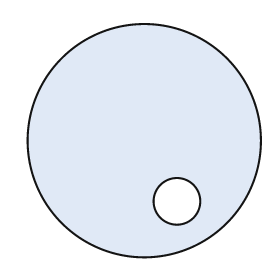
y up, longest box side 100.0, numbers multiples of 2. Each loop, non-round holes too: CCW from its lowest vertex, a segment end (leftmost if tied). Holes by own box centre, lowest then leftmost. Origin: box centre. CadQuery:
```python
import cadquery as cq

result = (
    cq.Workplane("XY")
    .moveTo(0.0, 0.0)
    .circle(50.0)
    .moveTo(14.0, -26.0)
    .circle(10.0)
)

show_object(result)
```